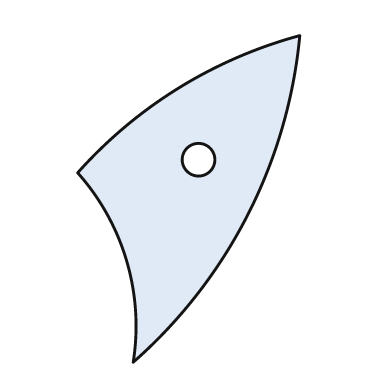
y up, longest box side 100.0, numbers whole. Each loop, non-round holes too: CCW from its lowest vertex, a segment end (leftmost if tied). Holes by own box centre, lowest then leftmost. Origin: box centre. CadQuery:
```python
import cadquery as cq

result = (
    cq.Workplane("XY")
    .moveTo(-17.0, -50.0)
    .threePointArc((18.0, -5.0), (34.0, 50.0))
    .threePointArc((-3.0, 34.0), (-34.0, 8.0))
    .threePointArc((-19.0, -19.0), (-17.0, -50.0))
    .close()
    .moveTo(3.0, 12.0)
    .circle(5.0)
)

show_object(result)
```